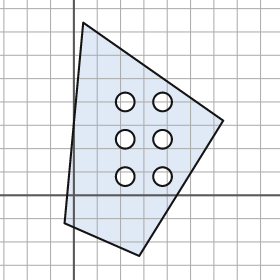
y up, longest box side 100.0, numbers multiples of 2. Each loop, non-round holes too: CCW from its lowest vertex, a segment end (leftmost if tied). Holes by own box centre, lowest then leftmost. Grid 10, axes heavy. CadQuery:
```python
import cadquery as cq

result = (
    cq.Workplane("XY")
    .moveTo(28.0, -26.0)
    .lineTo(64.0, 32.0)
    .lineTo(4.0, 74.0)
    .lineTo(-4.0, -12.0)
    .close()
    .moveTo(22.0, 8.0)
    .circle(4.0)
    .moveTo(38.0, 8.0)
    .circle(4.0)
    .moveTo(22.0, 24.0)
    .circle(4.0)
    .moveTo(38.0, 24.0)
    .circle(4.0)
    .moveTo(22.0, 40.0)
    .circle(4.0)
    .moveTo(38.0, 40.0)
    .circle(4.0)
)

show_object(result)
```